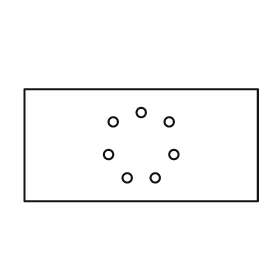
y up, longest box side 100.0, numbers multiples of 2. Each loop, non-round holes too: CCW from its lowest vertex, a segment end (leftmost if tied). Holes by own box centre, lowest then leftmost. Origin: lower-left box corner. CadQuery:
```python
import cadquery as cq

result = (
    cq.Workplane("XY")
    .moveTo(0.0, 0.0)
    .lineTo(100.0, 0.0)
    .lineTo(100.0, 48.0)
    .lineTo(0.0, 48.0)
    .close()
    .moveTo(44.0, 10.0)
    .circle(2.0)
    .moveTo(56.0, 10.0)
    .circle(2.0)
    .moveTo(36.0, 20.0)
    .circle(2.0)
    .moveTo(64.0, 20.0)
    .circle(2.0)
    .moveTo(38.0, 34.0)
    .circle(2.0)
    .moveTo(62.0, 34.0)
    .circle(2.0)
    .moveTo(50.0, 38.0)
    .circle(2.0)
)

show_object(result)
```